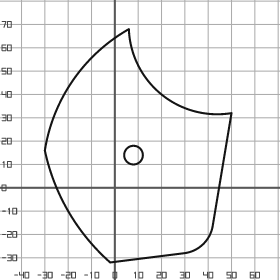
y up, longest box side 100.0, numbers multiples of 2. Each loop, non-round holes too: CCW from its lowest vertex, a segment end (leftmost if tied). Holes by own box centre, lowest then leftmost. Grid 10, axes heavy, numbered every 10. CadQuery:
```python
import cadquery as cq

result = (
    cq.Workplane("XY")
    .moveTo(-2.0, -32.0)
    .lineTo(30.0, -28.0)
    .threePointArc((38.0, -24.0), (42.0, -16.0))
    .lineTo(50.0, 32.0)
    .threePointArc((20.0, 40.0), (6.0, 68.0))
    .threePointArc((-18.0, 46.0), (-30.0, 16.0))
    .threePointArc((-20.0, -10.0), (-2.0, -32.0))
    .close()
    .moveTo(8.0, 14.0)
    .circle(4.0)
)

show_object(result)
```